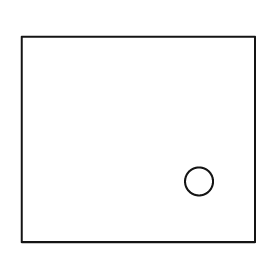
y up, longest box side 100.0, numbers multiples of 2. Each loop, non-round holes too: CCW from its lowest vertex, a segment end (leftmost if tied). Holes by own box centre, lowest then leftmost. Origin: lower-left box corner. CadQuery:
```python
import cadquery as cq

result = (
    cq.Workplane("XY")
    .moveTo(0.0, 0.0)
    .lineTo(100.0, 0.0)
    .lineTo(100.0, 88.0)
    .lineTo(0.0, 88.0)
    .close()
    .moveTo(76.0, 26.0)
    .circle(6.0)
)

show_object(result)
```